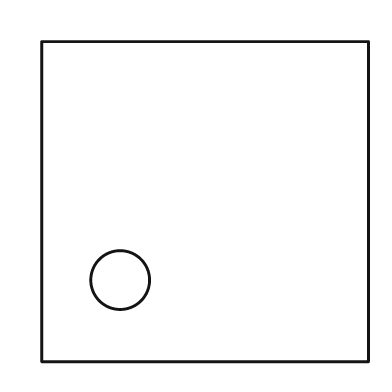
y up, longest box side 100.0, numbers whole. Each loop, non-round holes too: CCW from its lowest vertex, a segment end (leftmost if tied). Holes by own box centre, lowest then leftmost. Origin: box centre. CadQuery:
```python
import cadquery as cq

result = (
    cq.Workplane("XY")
    .moveTo(-50.0, -49.0)
    .lineTo(50.0, -49.0)
    .lineTo(50.0, 49.0)
    .lineTo(-50.0, 49.0)
    .close()
    .moveTo(-26.0, -24.0)
    .circle(9.0)
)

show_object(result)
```